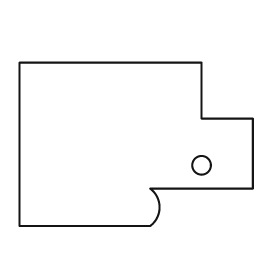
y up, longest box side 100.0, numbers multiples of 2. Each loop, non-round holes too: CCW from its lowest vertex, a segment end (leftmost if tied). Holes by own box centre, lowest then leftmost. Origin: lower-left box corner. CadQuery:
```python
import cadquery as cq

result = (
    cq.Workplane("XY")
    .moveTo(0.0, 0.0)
    .lineTo(56.0, 0.0)
    .threePointArc((60.0, 8.0), (56.0, 16.0))
    .lineTo(100.0, 16.0)
    .lineTo(100.0, 46.0)
    .lineTo(78.0, 46.0)
    .lineTo(78.0, 70.0)
    .lineTo(0.0, 70.0)
    .close()
    .moveTo(78.0, 26.0)
    .circle(4.0)
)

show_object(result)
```